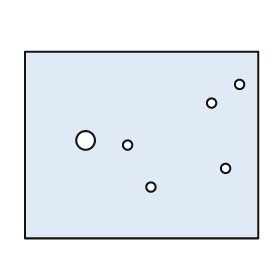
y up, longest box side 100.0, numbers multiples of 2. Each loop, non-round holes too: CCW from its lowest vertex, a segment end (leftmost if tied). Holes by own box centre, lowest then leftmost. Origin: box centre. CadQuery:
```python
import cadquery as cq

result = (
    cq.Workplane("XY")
    .moveTo(-50.0, -40.0)
    .lineTo(50.0, -40.0)
    .lineTo(50.0, 40.0)
    .lineTo(-50.0, 40.0)
    .close()
    .moveTo(4.0, -18.0)
    .circle(2.0)
    .moveTo(36.0, -10.0)
    .circle(2.0)
    .moveTo(-6.0, 0.0)
    .circle(2.0)
    .moveTo(-24.0, 2.0)
    .circle(4.0)
    .moveTo(30.0, 18.0)
    .circle(2.0)
    .moveTo(42.0, 26.0)
    .circle(2.0)
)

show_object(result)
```